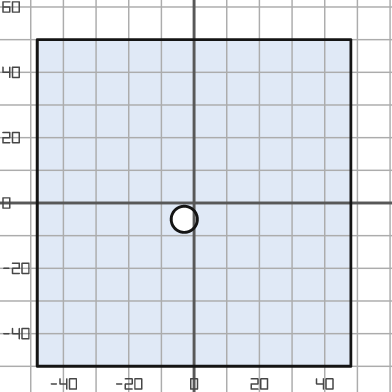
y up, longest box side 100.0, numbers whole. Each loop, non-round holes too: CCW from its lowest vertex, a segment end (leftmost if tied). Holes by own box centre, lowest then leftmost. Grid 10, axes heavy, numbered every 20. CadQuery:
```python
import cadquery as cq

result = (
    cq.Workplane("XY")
    .moveTo(-48.0, -50.0)
    .lineTo(48.0, -50.0)
    .lineTo(48.0, 50.0)
    .lineTo(-48.0, 50.0)
    .close()
    .moveTo(-3.0, -5.0)
    .circle(4.0)
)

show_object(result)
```